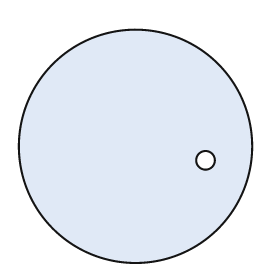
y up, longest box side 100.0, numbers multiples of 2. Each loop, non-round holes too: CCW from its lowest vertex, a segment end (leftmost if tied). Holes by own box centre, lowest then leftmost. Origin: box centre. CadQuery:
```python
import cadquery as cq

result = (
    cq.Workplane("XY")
    .moveTo(0.0, 0.0)
    .circle(50.0)
    .moveTo(30.0, -6.0)
    .circle(4.0)
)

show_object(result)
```